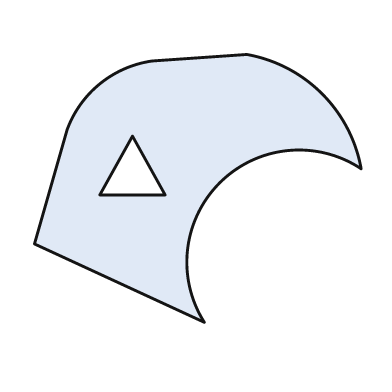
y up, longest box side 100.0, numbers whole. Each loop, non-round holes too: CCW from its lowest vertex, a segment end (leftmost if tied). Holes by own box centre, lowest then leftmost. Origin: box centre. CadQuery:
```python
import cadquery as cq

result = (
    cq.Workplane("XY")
    .moveTo(2.0, -41.0)
    .threePointArc((7.0, 2.0), (50.0, 6.0))
    .threePointArc((38.0, 29.0), (15.0, 41.0))
    .lineTo(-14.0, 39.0)
    .threePointArc((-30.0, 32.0), (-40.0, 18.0))
    .lineTo(-50.0, -17.0)
    .close()
    .moveTo(-30.0, -2.0)
    .lineTo(-10.0, -2.0)
    .lineTo(-20.0, 16.0)
    .close()
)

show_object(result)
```